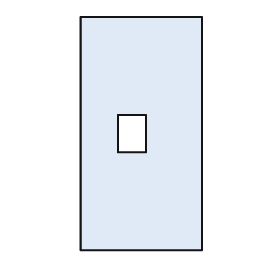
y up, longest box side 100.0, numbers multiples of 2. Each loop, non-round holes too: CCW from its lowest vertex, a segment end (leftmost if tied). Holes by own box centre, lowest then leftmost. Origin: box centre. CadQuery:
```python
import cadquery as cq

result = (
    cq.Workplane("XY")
    .moveTo(-26.0, -50.0)
    .lineTo(26.0, -50.0)
    .lineTo(26.0, 50.0)
    .lineTo(-26.0, 50.0)
    .close()
    .moveTo(-10.0, -8.0)
    .lineTo(2.0, -8.0)
    .lineTo(2.0, 8.0)
    .lineTo(-10.0, 8.0)
    .close()
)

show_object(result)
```